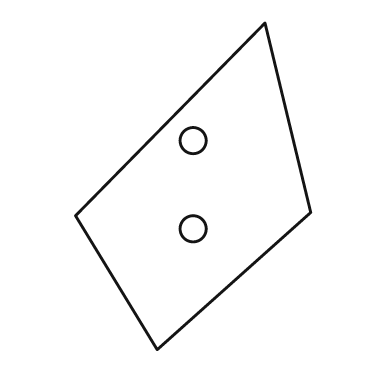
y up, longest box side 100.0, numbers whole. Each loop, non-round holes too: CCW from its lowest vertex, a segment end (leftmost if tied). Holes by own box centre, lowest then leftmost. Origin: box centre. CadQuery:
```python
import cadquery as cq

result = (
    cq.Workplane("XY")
    .moveTo(-11.0, -50.0)
    .lineTo(36.0, -8.0)
    .lineTo(22.0, 50.0)
    .lineTo(-36.0, -9.0)
    .close()
    .moveTo(0.0, -13.0)
    .circle(4.0)
    .moveTo(0.0, 14.0)
    .circle(4.0)
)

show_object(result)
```